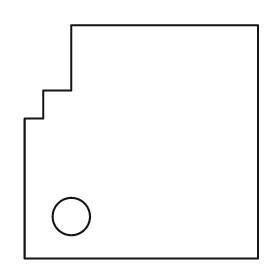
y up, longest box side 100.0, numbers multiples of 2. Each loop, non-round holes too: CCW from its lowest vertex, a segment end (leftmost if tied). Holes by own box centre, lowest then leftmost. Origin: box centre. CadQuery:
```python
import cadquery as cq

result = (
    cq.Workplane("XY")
    .moveTo(-50.0, -50.0)
    .lineTo(50.0, -50.0)
    .lineTo(50.0, 50.0)
    .lineTo(-30.0, 50.0)
    .lineTo(-30.0, 22.0)
    .lineTo(-42.0, 22.0)
    .lineTo(-42.0, 10.0)
    .lineTo(-50.0, 10.0)
    .close()
    .moveTo(-30.0, -32.0)
    .circle(8.0)
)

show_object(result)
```